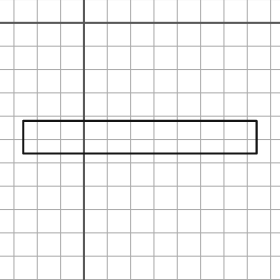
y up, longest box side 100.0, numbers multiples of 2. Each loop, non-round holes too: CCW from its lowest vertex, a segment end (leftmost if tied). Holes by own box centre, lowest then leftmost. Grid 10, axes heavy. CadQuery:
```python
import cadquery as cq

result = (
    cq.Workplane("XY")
    .moveTo(-26.0, -56.0)
    .lineTo(74.0, -56.0)
    .lineTo(74.0, -42.0)
    .lineTo(-26.0, -42.0)
    .close()
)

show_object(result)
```